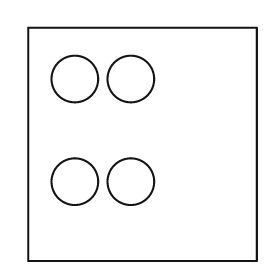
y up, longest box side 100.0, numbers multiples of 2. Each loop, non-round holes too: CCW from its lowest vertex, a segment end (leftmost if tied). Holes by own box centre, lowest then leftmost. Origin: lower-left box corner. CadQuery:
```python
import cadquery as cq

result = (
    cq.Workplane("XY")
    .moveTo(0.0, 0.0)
    .lineTo(98.0, 0.0)
    .lineTo(98.0, 100.0)
    .lineTo(0.0, 100.0)
    .close()
    .moveTo(20.0, 34.0)
    .circle(10.0)
    .moveTo(44.0, 34.0)
    .circle(10.0)
    .moveTo(20.0, 78.0)
    .circle(10.0)
    .moveTo(44.0, 78.0)
    .circle(10.0)
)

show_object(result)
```